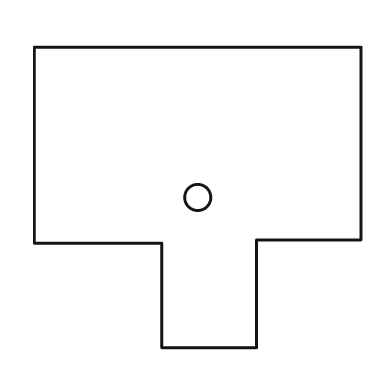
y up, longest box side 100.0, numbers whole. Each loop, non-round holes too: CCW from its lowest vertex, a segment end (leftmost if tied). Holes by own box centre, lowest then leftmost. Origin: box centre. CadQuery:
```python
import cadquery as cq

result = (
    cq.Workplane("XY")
    .moveTo(-11.0, -46.0)
    .lineTo(18.0, -46.0)
    .lineTo(18.0, -13.0)
    .lineTo(50.0, -13.0)
    .lineTo(50.0, 46.0)
    .lineTo(-50.0, 46.0)
    .lineTo(-50.0, -14.0)
    .lineTo(-11.0, -14.0)
    .close()
    .moveTo(0.0, 0.0)
    .circle(4.0)
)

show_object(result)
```